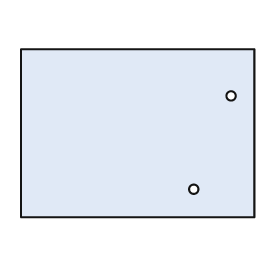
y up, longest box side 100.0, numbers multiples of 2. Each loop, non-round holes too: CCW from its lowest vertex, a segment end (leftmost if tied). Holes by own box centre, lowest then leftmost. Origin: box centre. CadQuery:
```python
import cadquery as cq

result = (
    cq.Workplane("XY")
    .moveTo(-50.0, -36.0)
    .lineTo(50.0, -36.0)
    .lineTo(50.0, 36.0)
    .lineTo(-50.0, 36.0)
    .close()
    .moveTo(24.0, -24.0)
    .circle(2.0)
    .moveTo(40.0, 16.0)
    .circle(2.0)
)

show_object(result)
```